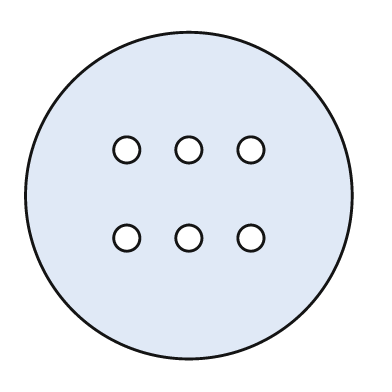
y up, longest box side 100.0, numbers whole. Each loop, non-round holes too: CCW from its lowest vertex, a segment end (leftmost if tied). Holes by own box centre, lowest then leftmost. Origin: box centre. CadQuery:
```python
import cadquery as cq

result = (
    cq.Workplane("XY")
    .moveTo(0.0, 0.0)
    .circle(50.0)
    .moveTo(-19.0, -13.0)
    .circle(4.0)
    .moveTo(0.0, -13.0)
    .circle(4.0)
    .moveTo(19.0, -13.0)
    .circle(4.0)
    .moveTo(-19.0, 14.0)
    .circle(4.0)
    .moveTo(0.0, 14.0)
    .circle(4.0)
    .moveTo(19.0, 14.0)
    .circle(4.0)
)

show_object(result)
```